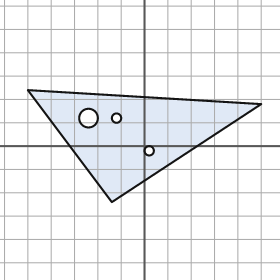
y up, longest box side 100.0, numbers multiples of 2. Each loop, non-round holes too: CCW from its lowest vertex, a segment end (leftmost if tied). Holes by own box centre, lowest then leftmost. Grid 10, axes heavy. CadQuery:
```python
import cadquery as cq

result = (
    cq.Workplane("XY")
    .moveTo(-14.0, -24.0)
    .lineTo(50.0, 18.0)
    .lineTo(-50.0, 24.0)
    .close()
    .moveTo(2.0, -2.0)
    .circle(2.0)
    .moveTo(-24.0, 12.0)
    .circle(4.0)
    .moveTo(-12.0, 12.0)
    .circle(2.0)
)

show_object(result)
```